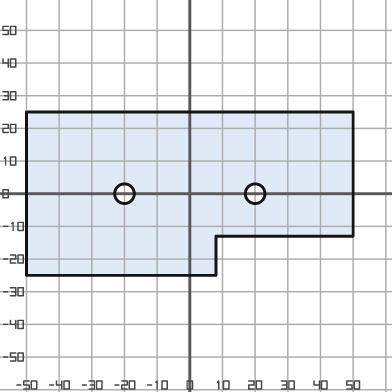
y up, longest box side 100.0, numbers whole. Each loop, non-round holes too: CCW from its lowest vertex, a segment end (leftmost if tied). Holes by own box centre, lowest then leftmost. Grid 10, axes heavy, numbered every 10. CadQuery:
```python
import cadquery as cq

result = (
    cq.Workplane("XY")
    .moveTo(-50.0, -25.0)
    .lineTo(8.0, -25.0)
    .lineTo(8.0, -13.0)
    .lineTo(50.0, -13.0)
    .lineTo(50.0, 25.0)
    .lineTo(-50.0, 25.0)
    .close()
    .moveTo(-20.0, 0.0)
    .circle(3.0)
    .moveTo(20.0, 0.0)
    .circle(3.0)
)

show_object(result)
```